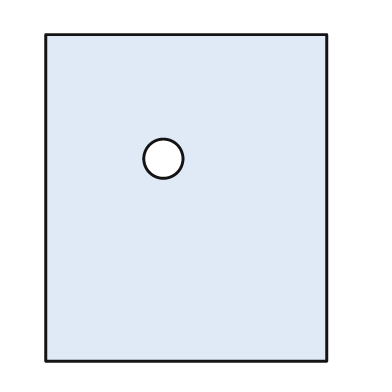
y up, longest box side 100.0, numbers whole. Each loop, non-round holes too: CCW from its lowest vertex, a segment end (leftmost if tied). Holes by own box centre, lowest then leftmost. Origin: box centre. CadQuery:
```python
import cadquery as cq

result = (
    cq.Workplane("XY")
    .moveTo(-43.0, -50.0)
    .lineTo(43.0, -50.0)
    .lineTo(43.0, 50.0)
    .lineTo(-43.0, 50.0)
    .close()
    .moveTo(-7.0, 12.0)
    .circle(6.0)
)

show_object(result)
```